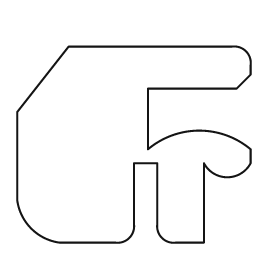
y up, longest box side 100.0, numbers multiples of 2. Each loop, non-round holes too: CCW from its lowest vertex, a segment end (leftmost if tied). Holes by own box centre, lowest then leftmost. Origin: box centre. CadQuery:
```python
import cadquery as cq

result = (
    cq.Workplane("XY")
    .moveTo(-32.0, -42.0)
    .lineTo(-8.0, -42.0)
    .threePointArc((-2.0, -40.0), (0.0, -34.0))
    .lineTo(0.0, -8.0)
    .lineTo(10.0, -8.0)
    .lineTo(10.0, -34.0)
    .threePointArc((12.0, -40.0), (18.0, -42.0))
    .lineTo(30.0, -42.0)
    .lineTo(30.0, -8.0)
    .threePointArc((40.0, -14.0), (50.0, -8.0))
    .lineTo(50.0, -2.0)
    .threePointArc((28.0, 6.0), (6.0, -2.0))
    .lineTo(6.0, 24.0)
    .lineTo(44.0, 24.0)
    .lineTo(50.0, 30.0)
    .lineTo(50.0, 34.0)
    .threePointArc((48.0, 40.0), (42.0, 42.0))
    .lineTo(-28.0, 42.0)
    .lineTo(-50.0, 14.0)
    .lineTo(-50.0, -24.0)
    .threePointArc((-44.0, -36.0), (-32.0, -42.0))
    .close()
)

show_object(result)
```